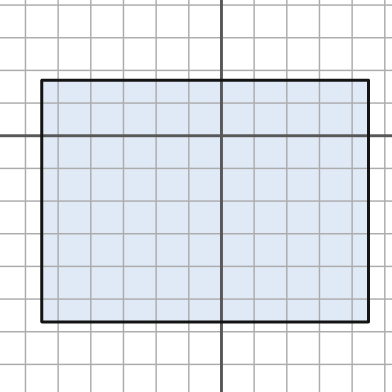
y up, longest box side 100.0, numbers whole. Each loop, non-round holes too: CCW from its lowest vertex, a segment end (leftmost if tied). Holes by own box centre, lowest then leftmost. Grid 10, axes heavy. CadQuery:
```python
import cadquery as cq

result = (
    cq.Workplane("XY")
    .moveTo(-55.0, -57.0)
    .lineTo(45.0, -57.0)
    .lineTo(45.0, 17.0)
    .lineTo(-55.0, 17.0)
    .close()
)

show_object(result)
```